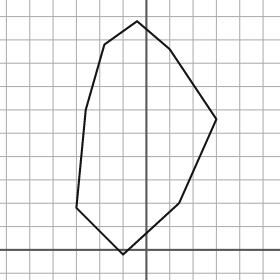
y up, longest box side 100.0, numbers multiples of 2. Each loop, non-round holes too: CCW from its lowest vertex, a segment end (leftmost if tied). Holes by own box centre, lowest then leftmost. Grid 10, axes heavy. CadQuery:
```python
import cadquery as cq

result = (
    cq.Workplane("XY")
    .moveTo(-10.0, -2.0)
    .lineTo(14.0, 20.0)
    .lineTo(30.0, 56.0)
    .lineTo(10.0, 86.0)
    .lineTo(-4.0, 98.0)
    .lineTo(-18.0, 88.0)
    .lineTo(-26.0, 60.0)
    .lineTo(-30.0, 18.0)
    .close()
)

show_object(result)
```